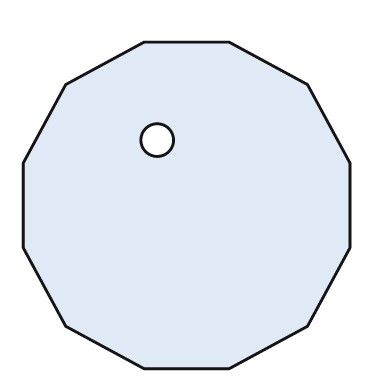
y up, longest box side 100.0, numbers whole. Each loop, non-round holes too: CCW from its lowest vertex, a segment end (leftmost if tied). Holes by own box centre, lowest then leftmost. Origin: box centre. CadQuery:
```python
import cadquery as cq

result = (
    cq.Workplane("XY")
    .moveTo(-13.0, -50.0)
    .lineTo(13.0, -50.0)
    .lineTo(37.0, -37.0)
    .lineTo(50.0, -13.0)
    .lineTo(50.0, 13.0)
    .lineTo(37.0, 37.0)
    .lineTo(13.0, 50.0)
    .lineTo(-13.0, 50.0)
    .lineTo(-37.0, 37.0)
    .lineTo(-50.0, 13.0)
    .lineTo(-50.0, -13.0)
    .lineTo(-37.0, -37.0)
    .close()
    .moveTo(-9.0, 20.0)
    .circle(5.0)
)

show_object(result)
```